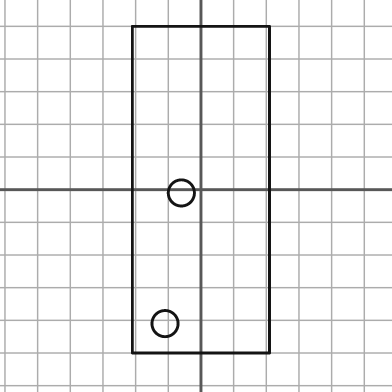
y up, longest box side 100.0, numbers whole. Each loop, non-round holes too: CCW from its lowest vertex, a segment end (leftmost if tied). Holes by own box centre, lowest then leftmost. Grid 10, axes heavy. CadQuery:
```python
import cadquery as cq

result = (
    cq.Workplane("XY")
    .moveTo(-21.0, -50.0)
    .lineTo(21.0, -50.0)
    .lineTo(21.0, 50.0)
    .lineTo(-21.0, 50.0)
    .close()
    .moveTo(-11.0, -41.0)
    .circle(4.0)
    .moveTo(-6.0, -1.0)
    .circle(4.0)
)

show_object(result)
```